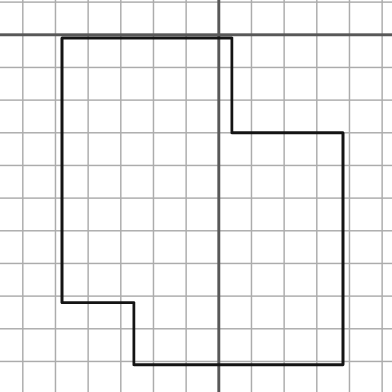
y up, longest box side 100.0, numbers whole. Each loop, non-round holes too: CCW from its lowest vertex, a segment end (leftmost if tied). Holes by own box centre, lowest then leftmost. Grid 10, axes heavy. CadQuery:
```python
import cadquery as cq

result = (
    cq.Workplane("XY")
    .moveTo(-26.0, -101.0)
    .lineTo(38.0, -101.0)
    .lineTo(38.0, -30.0)
    .lineTo(4.0, -30.0)
    .lineTo(4.0, -1.0)
    .lineTo(-48.0, -1.0)
    .lineTo(-48.0, -82.0)
    .lineTo(-26.0, -82.0)
    .close()
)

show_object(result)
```